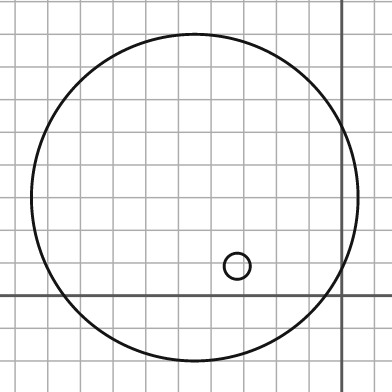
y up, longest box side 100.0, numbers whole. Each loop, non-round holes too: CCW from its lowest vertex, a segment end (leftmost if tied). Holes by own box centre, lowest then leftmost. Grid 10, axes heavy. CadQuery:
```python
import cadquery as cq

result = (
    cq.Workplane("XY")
    .moveTo(-45.0, 30.0)
    .circle(50.0)
    .moveTo(-32.0, 9.0)
    .circle(4.0)
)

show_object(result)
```